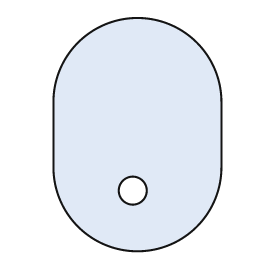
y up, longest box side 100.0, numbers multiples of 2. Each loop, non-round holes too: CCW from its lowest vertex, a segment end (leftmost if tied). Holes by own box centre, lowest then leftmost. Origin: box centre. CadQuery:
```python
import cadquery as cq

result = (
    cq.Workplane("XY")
    .moveTo(-36.0, -14.0)
    .threePointArc((0.0, -50.0), (36.0, -14.0))
    .lineTo(36.0, 14.0)
    .threePointArc((0.0, 50.0), (-36.0, 14.0))
    .close()
    .moveTo(-2.0, -24.0)
    .circle(6.0)
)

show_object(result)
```